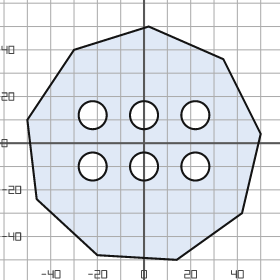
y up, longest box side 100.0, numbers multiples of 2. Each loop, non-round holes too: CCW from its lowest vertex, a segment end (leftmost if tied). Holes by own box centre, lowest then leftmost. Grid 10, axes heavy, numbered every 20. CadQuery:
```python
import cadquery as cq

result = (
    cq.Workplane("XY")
    .moveTo(14.0, -50.0)
    .lineTo(42.0, -30.0)
    .lineTo(50.0, 4.0)
    .lineTo(34.0, 36.0)
    .lineTo(2.0, 50.0)
    .lineTo(-30.0, 40.0)
    .lineTo(-50.0, 10.0)
    .lineTo(-46.0, -24.0)
    .lineTo(-20.0, -48.0)
    .close()
    .moveTo(-22.0, -10.0)
    .circle(6.0)
    .moveTo(0.0, -10.0)
    .circle(6.0)
    .moveTo(22.0, -10.0)
    .circle(6.0)
    .moveTo(-22.0, 12.0)
    .circle(6.0)
    .moveTo(0.0, 12.0)
    .circle(6.0)
    .moveTo(22.0, 12.0)
    .circle(6.0)
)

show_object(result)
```